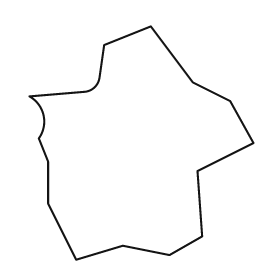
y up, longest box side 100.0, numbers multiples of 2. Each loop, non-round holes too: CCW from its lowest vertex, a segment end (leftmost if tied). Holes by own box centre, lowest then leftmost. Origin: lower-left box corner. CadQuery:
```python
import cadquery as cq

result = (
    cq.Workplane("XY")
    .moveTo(20.0, 0.0)
    .lineTo(40.0, 6.0)
    .lineTo(60.0, 2.0)
    .lineTo(74.0, 10.0)
    .lineTo(72.0, 38.0)
    .lineTo(96.0, 50.0)
    .lineTo(86.0, 68.0)
    .lineTo(70.0, 76.0)
    .lineTo(52.0, 100.0)
    .lineTo(32.0, 92.0)
    .lineTo(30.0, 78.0)
    .threePointArc((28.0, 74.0), (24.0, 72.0))
    .lineTo(0.0, 70.0)
    .threePointArc((6.0, 62.0), (4.0, 52.0))
    .lineTo(8.0, 42.0)
    .lineTo(8.0, 24.0)
    .close()
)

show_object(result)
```